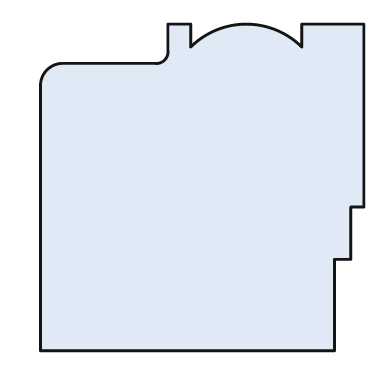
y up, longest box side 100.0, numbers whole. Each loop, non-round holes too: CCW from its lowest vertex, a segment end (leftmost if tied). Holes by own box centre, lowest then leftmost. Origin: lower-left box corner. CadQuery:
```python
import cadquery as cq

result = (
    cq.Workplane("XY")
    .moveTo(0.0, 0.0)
    .lineTo(90.0, 0.0)
    .lineTo(90.0, 28.0)
    .lineTo(95.0, 28.0)
    .lineTo(95.0, 44.0)
    .lineTo(99.0, 44.0)
    .lineTo(99.0, 100.0)
    .lineTo(80.0, 100.0)
    .lineTo(80.0, 93.0)
    .threePointArc((63.0, 100.0), (46.0, 93.0))
    .lineTo(46.0, 100.0)
    .lineTo(39.0, 100.0)
    .lineTo(39.0, 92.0)
    .threePointArc((38.0, 89.0), (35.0, 88.0))
    .lineTo(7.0, 88.0)
    .threePointArc((2.0, 86.0), (0.0, 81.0))
    .close()
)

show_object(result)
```